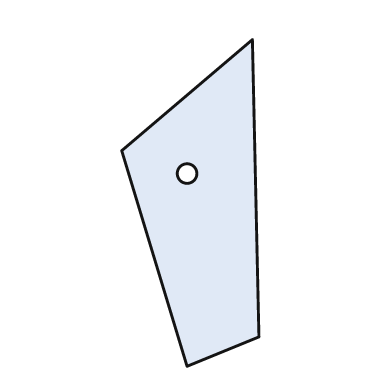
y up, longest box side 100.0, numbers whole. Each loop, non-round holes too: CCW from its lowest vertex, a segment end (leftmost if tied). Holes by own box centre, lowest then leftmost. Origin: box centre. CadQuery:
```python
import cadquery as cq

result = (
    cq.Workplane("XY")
    .moveTo(-1.0, -50.0)
    .lineTo(21.0, -41.0)
    .lineTo(19.0, 50.0)
    .lineTo(-21.0, 16.0)
    .close()
    .moveTo(-1.0, 9.0)
    .circle(3.0)
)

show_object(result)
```